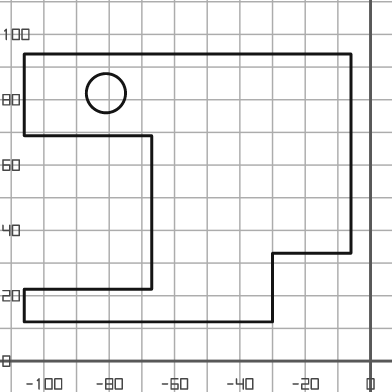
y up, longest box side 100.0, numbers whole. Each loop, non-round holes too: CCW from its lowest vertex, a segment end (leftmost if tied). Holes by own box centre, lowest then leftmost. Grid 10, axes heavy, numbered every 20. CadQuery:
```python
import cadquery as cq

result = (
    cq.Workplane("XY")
    .moveTo(-106.0, 12.0)
    .lineTo(-30.0, 12.0)
    .lineTo(-30.0, 33.0)
    .lineTo(-6.0, 33.0)
    .lineTo(-6.0, 94.0)
    .lineTo(-106.0, 94.0)
    .lineTo(-106.0, 69.0)
    .lineTo(-67.0, 69.0)
    .lineTo(-67.0, 22.0)
    .lineTo(-106.0, 22.0)
    .close()
    .moveTo(-81.0, 82.0)
    .circle(6.0)
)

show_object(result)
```